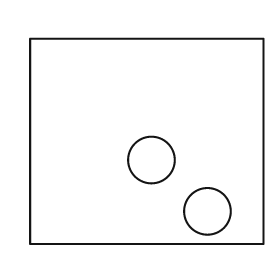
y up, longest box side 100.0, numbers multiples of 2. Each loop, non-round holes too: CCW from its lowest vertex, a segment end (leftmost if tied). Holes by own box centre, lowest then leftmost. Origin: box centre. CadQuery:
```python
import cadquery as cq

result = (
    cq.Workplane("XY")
    .moveTo(-50.0, -44.0)
    .lineTo(50.0, -44.0)
    .lineTo(50.0, 44.0)
    .lineTo(-50.0, 44.0)
    .close()
    .moveTo(26.0, -30.0)
    .circle(10.0)
    .moveTo(2.0, -8.0)
    .circle(10.0)
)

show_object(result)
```